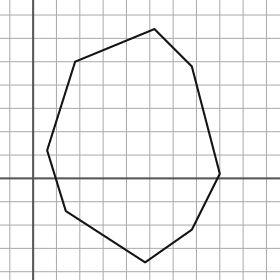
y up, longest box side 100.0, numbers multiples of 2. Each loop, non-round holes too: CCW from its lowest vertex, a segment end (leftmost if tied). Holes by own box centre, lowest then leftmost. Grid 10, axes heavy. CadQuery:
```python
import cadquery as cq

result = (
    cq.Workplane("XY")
    .moveTo(48.0, -36.0)
    .lineTo(68.0, -22.0)
    .lineTo(80.0, 2.0)
    .lineTo(68.0, 48.0)
    .lineTo(52.0, 64.0)
    .lineTo(18.0, 50.0)
    .lineTo(6.0, 12.0)
    .lineTo(14.0, -14.0)
    .close()
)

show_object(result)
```